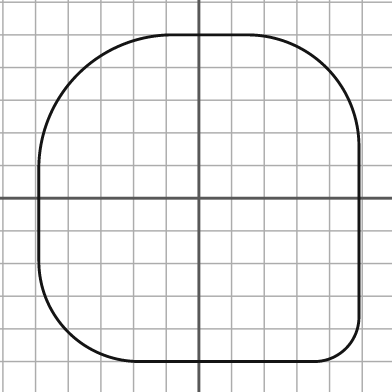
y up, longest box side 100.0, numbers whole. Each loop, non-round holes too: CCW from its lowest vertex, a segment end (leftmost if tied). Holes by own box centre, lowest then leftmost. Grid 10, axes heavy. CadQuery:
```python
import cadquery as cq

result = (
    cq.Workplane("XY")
    .moveTo(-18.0, -50.0)
    .lineTo(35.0, -50.0)
    .threePointArc((45.0, -46.0), (49.0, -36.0))
    .lineTo(49.0, 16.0)
    .threePointArc((39.0, 40.0), (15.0, 50.0))
    .lineTo(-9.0, 50.0)
    .threePointArc((-37.0, 38.0), (-49.0, 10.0))
    .lineTo(-49.0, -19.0)
    .threePointArc((-40.0, -41.0), (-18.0, -50.0))
    .close()
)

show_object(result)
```